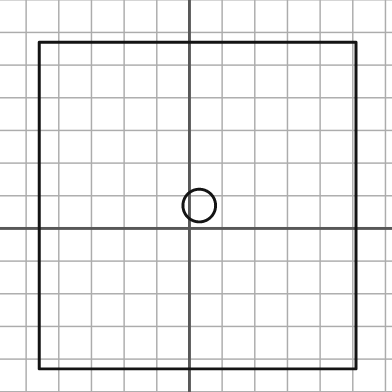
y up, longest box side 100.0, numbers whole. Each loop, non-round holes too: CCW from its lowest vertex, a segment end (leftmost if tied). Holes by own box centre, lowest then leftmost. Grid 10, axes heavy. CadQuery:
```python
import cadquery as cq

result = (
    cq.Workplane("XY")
    .moveTo(-46.0, -43.0)
    .lineTo(51.0, -43.0)
    .lineTo(51.0, 57.0)
    .lineTo(-46.0, 57.0)
    .close()
    .moveTo(3.0, 7.0)
    .circle(5.0)
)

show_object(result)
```